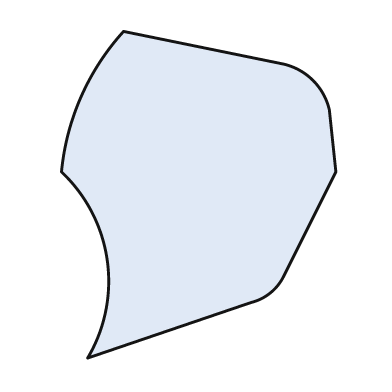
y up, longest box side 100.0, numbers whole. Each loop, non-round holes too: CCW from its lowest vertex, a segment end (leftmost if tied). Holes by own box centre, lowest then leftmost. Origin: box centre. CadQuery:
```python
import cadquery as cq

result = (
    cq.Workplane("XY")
    .moveTo(-34.0, -50.0)
    .lineTo(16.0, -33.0)
    .threePointArc((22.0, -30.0), (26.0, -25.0))
    .lineTo(42.0, 7.0)
    .lineTo(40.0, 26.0)
    .threePointArc((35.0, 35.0), (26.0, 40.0))
    .lineTo(-23.0, 50.0)
    .threePointArc((-36.0, 30.0), (-42.0, 7.0))
    .threePointArc((-28.0, -20.0), (-34.0, -50.0))
    .close()
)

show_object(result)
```